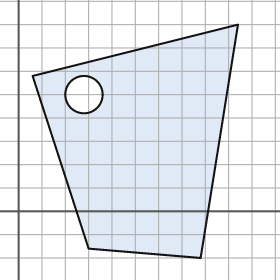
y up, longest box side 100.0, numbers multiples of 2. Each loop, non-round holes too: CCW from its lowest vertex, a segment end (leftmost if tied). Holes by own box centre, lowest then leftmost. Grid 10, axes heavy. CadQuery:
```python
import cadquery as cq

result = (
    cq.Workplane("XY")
    .moveTo(78.0, -20.0)
    .lineTo(94.0, 80.0)
    .lineTo(6.0, 58.0)
    .lineTo(30.0, -16.0)
    .close()
    .moveTo(28.0, 50.0)
    .circle(8.0)
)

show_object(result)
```